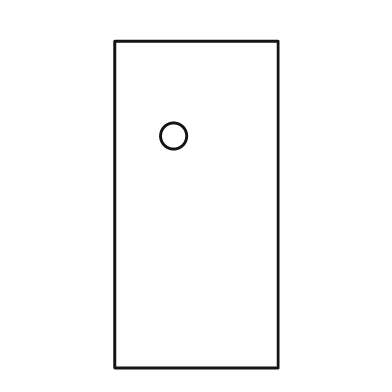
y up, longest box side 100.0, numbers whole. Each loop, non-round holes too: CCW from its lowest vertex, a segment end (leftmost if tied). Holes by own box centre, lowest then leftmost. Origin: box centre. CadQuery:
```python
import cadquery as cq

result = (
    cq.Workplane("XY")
    .moveTo(-25.0, -50.0)
    .lineTo(25.0, -50.0)
    .lineTo(25.0, 50.0)
    .lineTo(-25.0, 50.0)
    .close()
    .moveTo(-7.0, 21.0)
    .circle(4.0)
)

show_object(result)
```